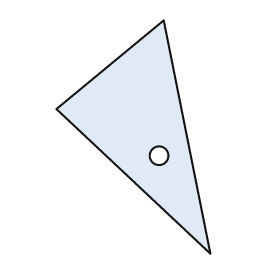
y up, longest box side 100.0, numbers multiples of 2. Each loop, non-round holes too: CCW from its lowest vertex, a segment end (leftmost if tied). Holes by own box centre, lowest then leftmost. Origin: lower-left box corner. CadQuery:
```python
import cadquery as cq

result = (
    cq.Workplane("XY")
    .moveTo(66.0, 0.0)
    .lineTo(46.0, 100.0)
    .lineTo(0.0, 62.0)
    .close()
    .moveTo(44.0, 42.0)
    .circle(4.0)
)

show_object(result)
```